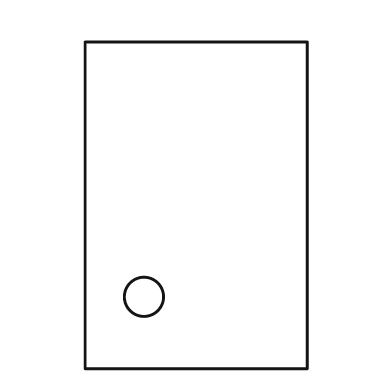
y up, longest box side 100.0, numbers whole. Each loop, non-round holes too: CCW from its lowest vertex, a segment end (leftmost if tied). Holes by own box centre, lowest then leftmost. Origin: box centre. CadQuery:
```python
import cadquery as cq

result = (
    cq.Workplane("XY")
    .moveTo(-34.0, -50.0)
    .lineTo(34.0, -50.0)
    .lineTo(34.0, 50.0)
    .lineTo(-34.0, 50.0)
    .close()
    .moveTo(-16.0, -28.0)
    .circle(6.0)
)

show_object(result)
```